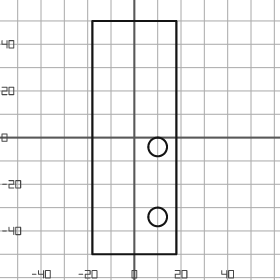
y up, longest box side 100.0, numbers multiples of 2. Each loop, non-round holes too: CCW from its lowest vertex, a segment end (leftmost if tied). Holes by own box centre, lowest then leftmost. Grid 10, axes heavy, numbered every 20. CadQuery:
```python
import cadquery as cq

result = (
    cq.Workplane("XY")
    .moveTo(-18.0, -50.0)
    .lineTo(18.0, -50.0)
    .lineTo(18.0, 50.0)
    .lineTo(-18.0, 50.0)
    .close()
    .moveTo(10.0, -34.0)
    .circle(4.0)
    .moveTo(10.0, -4.0)
    .circle(4.0)
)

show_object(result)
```